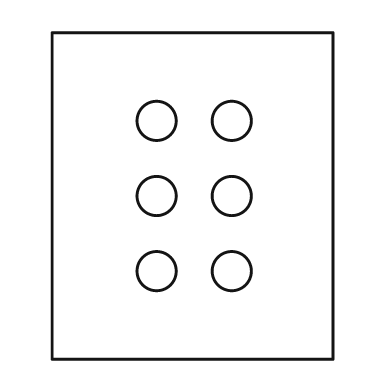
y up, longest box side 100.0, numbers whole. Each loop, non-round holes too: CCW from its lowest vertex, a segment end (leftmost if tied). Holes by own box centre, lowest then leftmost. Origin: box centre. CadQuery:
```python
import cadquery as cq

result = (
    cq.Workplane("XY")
    .moveTo(-43.0, -50.0)
    .lineTo(43.0, -50.0)
    .lineTo(43.0, 50.0)
    .lineTo(-43.0, 50.0)
    .close()
    .moveTo(-11.0, -23.0)
    .circle(6.0)
    .moveTo(12.0, -23.0)
    .circle(6.0)
    .moveTo(-11.0, 0.0)
    .circle(6.0)
    .moveTo(12.0, 0.0)
    .circle(6.0)
    .moveTo(-11.0, 23.0)
    .circle(6.0)
    .moveTo(12.0, 23.0)
    .circle(6.0)
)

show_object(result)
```